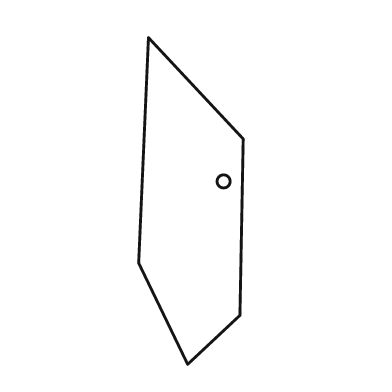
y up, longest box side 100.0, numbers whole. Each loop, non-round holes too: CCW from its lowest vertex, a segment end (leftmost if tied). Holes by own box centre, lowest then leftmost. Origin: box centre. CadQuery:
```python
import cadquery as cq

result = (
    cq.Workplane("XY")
    .moveTo(-1.0, -50.0)
    .lineTo(15.0, -35.0)
    .lineTo(16.0, 19.0)
    .lineTo(-13.0, 50.0)
    .lineTo(-16.0, -19.0)
    .close()
    .moveTo(10.0, 6.0)
    .circle(2.0)
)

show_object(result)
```